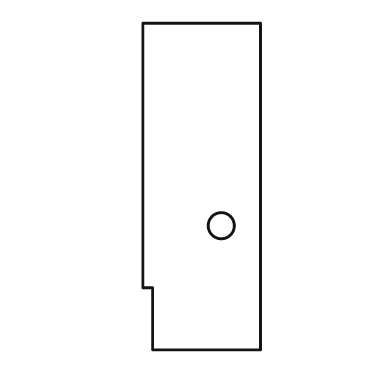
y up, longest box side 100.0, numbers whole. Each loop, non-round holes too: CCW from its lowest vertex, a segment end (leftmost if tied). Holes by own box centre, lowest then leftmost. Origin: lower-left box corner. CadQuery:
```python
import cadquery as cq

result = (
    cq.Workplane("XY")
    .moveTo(3.0, 0.0)
    .lineTo(36.0, 0.0)
    .lineTo(36.0, 100.0)
    .lineTo(0.0, 100.0)
    .lineTo(0.0, 19.0)
    .lineTo(3.0, 19.0)
    .close()
    .moveTo(24.0, 38.0)
    .circle(4.0)
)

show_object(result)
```